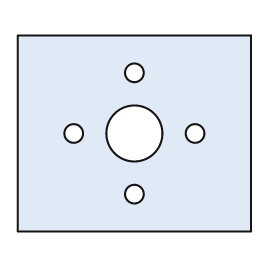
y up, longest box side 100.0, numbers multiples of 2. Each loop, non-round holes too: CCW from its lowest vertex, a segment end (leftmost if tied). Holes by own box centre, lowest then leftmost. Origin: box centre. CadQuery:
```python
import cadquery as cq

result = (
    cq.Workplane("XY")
    .moveTo(-50.0, -42.0)
    .lineTo(50.0, -42.0)
    .lineTo(50.0, 42.0)
    .lineTo(-50.0, 42.0)
    .close()
    .moveTo(0.0, -26.0)
    .circle(4.0)
    .moveTo(-26.0, 0.0)
    .circle(4.0)
    .moveTo(0.0, 0.0)
    .circle(12.0)
    .moveTo(26.0, 0.0)
    .circle(4.0)
    .moveTo(0.0, 26.0)
    .circle(4.0)
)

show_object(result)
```